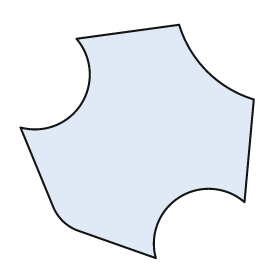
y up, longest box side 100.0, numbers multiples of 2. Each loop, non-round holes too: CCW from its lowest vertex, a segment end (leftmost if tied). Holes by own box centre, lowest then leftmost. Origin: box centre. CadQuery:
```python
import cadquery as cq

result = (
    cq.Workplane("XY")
    .moveTo(8.0, -50.0)
    .threePointArc((18.0, -24.0), (46.0, -26.0))
    .lineTo(50.0, 18.0)
    .threePointArc((30.0, 30.0), (18.0, 50.0))
    .lineTo(-26.0, 44.0)
    .threePointArc((-24.0, 16.0), (-50.0, 6.0))
    .lineTo(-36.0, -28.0)
    .threePointArc((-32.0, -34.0), (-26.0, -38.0))
    .close()
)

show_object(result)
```